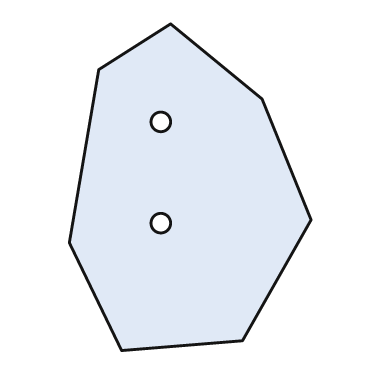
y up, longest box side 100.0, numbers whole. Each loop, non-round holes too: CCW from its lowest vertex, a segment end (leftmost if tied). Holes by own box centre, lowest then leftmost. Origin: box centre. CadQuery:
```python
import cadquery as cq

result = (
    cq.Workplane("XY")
    .moveTo(-21.0, -50.0)
    .lineTo(16.0, -47.0)
    .lineTo(37.0, -10.0)
    .lineTo(22.0, 27.0)
    .lineTo(-6.0, 50.0)
    .lineTo(-28.0, 36.0)
    .lineTo(-37.0, -17.0)
    .close()
    .moveTo(-9.0, -11.0)
    .circle(3.0)
    .moveTo(-9.0, 20.0)
    .circle(3.0)
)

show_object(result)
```